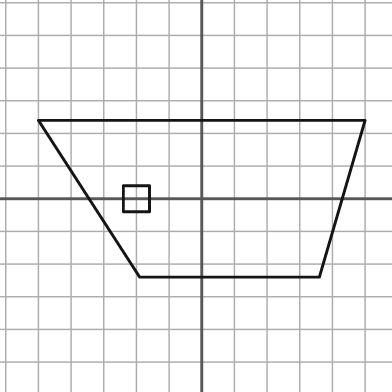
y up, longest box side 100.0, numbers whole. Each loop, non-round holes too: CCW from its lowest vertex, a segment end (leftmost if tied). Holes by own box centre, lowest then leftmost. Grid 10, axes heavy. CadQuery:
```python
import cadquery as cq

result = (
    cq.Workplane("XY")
    .moveTo(-19.0, -24.0)
    .lineTo(36.0, -24.0)
    .lineTo(50.0, 24.0)
    .lineTo(-50.0, 24.0)
    .close()
    .moveTo(-24.0, -4.0)
    .lineTo(-16.0, -4.0)
    .lineTo(-16.0, 4.0)
    .lineTo(-24.0, 4.0)
    .close()
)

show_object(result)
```